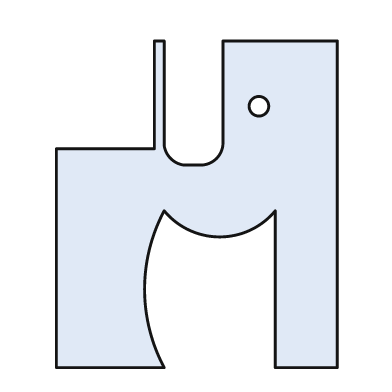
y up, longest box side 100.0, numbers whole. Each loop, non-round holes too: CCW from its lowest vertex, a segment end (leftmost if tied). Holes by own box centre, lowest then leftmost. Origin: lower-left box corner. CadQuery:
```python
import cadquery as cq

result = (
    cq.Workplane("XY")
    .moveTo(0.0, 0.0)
    .lineTo(33.0, 0.0)
    .threePointArc((27.0, 24.0), (33.0, 48.0))
    .threePointArc((50.0, 40.0), (67.0, 48.0))
    .lineTo(67.0, 0.0)
    .lineTo(86.0, 0.0)
    .lineTo(86.0, 100.0)
    .lineTo(51.0, 100.0)
    .lineTo(51.0, 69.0)
    .threePointArc((49.0, 64.0), (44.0, 62.0))
    .lineTo(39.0, 62.0)
    .threePointArc((35.0, 64.0), (33.0, 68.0))
    .lineTo(33.0, 100.0)
    .lineTo(30.0, 100.0)
    .lineTo(30.0, 67.0)
    .lineTo(0.0, 67.0)
    .close()
    .moveTo(62.0, 80.0)
    .circle(3.0)
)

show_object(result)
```